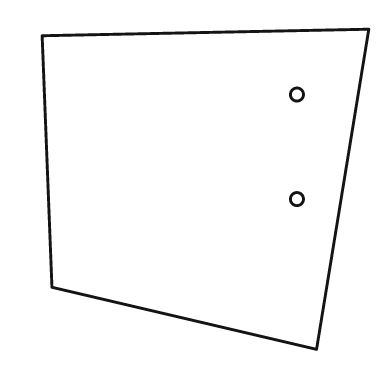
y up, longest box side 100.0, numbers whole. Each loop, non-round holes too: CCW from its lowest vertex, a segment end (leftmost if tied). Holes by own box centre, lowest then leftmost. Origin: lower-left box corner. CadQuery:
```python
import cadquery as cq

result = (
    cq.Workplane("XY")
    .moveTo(84.0, 0.0)
    .lineTo(100.0, 98.0)
    .lineTo(0.0, 96.0)
    .lineTo(3.0, 19.0)
    .close()
    .moveTo(78.0, 46.0)
    .circle(2.0)
    .moveTo(78.0, 78.0)
    .circle(2.0)
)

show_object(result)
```